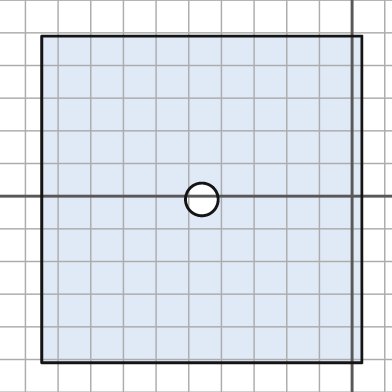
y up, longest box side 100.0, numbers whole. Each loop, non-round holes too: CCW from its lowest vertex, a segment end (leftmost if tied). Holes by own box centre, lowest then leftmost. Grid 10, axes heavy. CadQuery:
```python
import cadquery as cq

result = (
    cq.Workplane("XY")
    .moveTo(-95.0, -51.0)
    .lineTo(3.0, -51.0)
    .lineTo(3.0, 49.0)
    .lineTo(-95.0, 49.0)
    .close()
    .moveTo(-46.0, -1.0)
    .circle(5.0)
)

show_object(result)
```